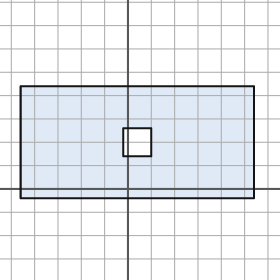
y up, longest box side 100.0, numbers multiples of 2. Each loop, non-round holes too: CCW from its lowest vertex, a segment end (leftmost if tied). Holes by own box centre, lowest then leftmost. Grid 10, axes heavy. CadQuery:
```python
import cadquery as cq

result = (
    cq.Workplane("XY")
    .moveTo(-46.0, -4.0)
    .lineTo(54.0, -4.0)
    .lineTo(54.0, 44.0)
    .lineTo(-46.0, 44.0)
    .close()
    .moveTo(-2.0, 14.0)
    .lineTo(10.0, 14.0)
    .lineTo(10.0, 26.0)
    .lineTo(-2.0, 26.0)
    .close()
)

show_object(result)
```